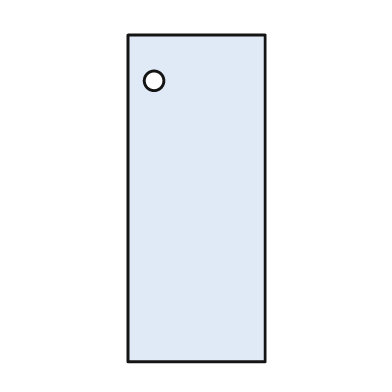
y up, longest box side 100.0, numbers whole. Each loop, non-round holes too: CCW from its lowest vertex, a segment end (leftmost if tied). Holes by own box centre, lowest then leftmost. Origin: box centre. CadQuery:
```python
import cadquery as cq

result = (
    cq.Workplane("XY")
    .moveTo(-21.0, -50.0)
    .lineTo(21.0, -50.0)
    .lineTo(21.0, 50.0)
    .lineTo(-21.0, 50.0)
    .close()
    .moveTo(-13.0, 36.0)
    .circle(3.0)
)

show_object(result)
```